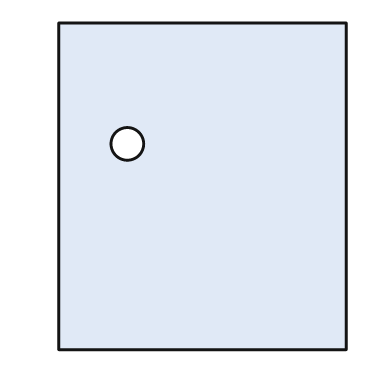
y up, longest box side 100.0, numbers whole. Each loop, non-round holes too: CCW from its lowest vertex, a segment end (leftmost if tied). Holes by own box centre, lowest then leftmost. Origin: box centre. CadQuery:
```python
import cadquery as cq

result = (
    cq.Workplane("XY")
    .moveTo(-44.0, -50.0)
    .lineTo(44.0, -50.0)
    .lineTo(44.0, 50.0)
    .lineTo(-44.0, 50.0)
    .close()
    .moveTo(-23.0, 13.0)
    .circle(5.0)
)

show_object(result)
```